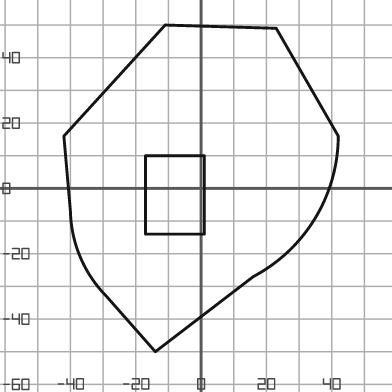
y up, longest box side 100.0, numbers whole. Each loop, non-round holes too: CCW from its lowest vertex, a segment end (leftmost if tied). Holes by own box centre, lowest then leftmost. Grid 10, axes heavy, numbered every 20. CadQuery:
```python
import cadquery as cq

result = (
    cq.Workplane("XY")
    .moveTo(-14.0, -50.0)
    .lineTo(16.0, -27.0)
    .threePointArc((35.0, -9.0), (42.0, 16.0))
    .lineTo(23.0, 49.0)
    .lineTo(-11.0, 50.0)
    .lineTo(-42.0, 16.0)
    .lineTo(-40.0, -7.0)
    .threePointArc((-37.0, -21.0), (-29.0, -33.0))
    .close()
    .moveTo(-17.0, -14.0)
    .lineTo(1.0, -14.0)
    .lineTo(1.0, 10.0)
    .lineTo(-17.0, 10.0)
    .close()
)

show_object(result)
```